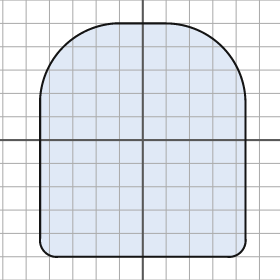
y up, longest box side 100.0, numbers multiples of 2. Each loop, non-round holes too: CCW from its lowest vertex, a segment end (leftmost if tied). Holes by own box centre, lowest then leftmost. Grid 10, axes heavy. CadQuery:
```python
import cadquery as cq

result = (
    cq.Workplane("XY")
    .moveTo(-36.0, -50.0)
    .lineTo(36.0, -50.0)
    .threePointArc((42.0, -48.0), (44.0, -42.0))
    .lineTo(44.0, 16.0)
    .threePointArc((34.0, 40.0), (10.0, 50.0))
    .lineTo(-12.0, 50.0)
    .threePointArc((-34.0, 40.0), (-44.0, 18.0))
    .lineTo(-44.0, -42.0)
    .threePointArc((-42.0, -48.0), (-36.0, -50.0))
    .close()
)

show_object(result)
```